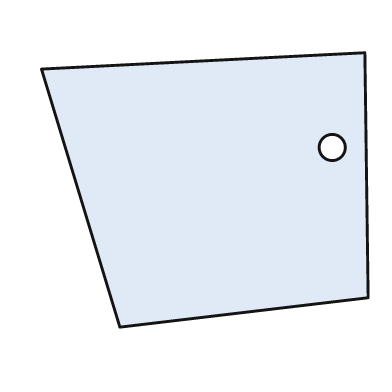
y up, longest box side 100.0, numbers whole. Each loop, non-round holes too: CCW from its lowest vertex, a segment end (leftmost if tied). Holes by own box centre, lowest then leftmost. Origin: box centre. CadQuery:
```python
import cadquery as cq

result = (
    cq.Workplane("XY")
    .moveTo(-26.0, -42.0)
    .lineTo(50.0, -33.0)
    .lineTo(49.0, 42.0)
    .lineTo(-50.0, 37.0)
    .close()
    .moveTo(39.0, 13.0)
    .circle(4.0)
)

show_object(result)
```